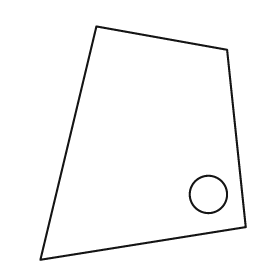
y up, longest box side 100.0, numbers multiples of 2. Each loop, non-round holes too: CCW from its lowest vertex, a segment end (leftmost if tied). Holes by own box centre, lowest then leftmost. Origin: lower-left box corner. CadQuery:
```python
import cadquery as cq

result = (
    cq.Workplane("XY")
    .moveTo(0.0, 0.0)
    .lineTo(88.0, 14.0)
    .lineTo(80.0, 90.0)
    .lineTo(24.0, 100.0)
    .close()
    .moveTo(72.0, 28.0)
    .circle(8.0)
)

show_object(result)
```